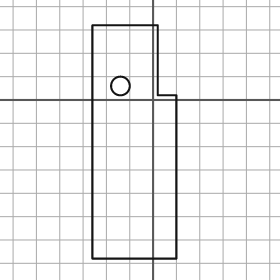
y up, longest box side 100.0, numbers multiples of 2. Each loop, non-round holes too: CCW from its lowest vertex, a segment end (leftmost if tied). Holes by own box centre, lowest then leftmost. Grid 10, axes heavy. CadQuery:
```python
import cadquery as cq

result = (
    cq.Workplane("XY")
    .moveTo(-26.0, -68.0)
    .lineTo(10.0, -68.0)
    .lineTo(10.0, 2.0)
    .lineTo(2.0, 2.0)
    .lineTo(2.0, 32.0)
    .lineTo(-26.0, 32.0)
    .close()
    .moveTo(-14.0, 6.0)
    .circle(4.0)
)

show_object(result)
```